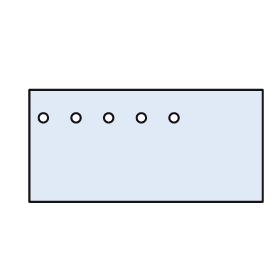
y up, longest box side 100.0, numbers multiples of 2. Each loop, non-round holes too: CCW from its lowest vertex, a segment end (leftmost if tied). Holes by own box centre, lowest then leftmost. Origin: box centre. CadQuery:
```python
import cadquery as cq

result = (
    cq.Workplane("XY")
    .moveTo(-50.0, -24.0)
    .lineTo(50.0, -24.0)
    .lineTo(50.0, 24.0)
    .lineTo(-50.0, 24.0)
    .close()
    .moveTo(-44.0, 12.0)
    .circle(2.0)
    .moveTo(-30.0, 12.0)
    .circle(2.0)
    .moveTo(-16.0, 12.0)
    .circle(2.0)
    .moveTo(-2.0, 12.0)
    .circle(2.0)
    .moveTo(12.0, 12.0)
    .circle(2.0)
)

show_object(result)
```